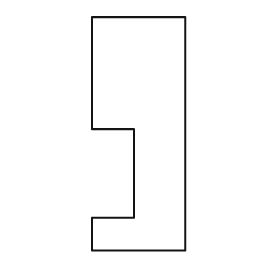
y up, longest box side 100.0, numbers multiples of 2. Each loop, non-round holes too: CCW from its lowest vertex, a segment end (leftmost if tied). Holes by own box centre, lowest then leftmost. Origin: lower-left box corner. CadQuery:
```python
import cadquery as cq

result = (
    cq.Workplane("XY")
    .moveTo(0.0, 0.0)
    .lineTo(40.0, 0.0)
    .lineTo(40.0, 100.0)
    .lineTo(0.0, 100.0)
    .lineTo(0.0, 52.0)
    .lineTo(18.0, 52.0)
    .lineTo(18.0, 14.0)
    .lineTo(0.0, 14.0)
    .close()
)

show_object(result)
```